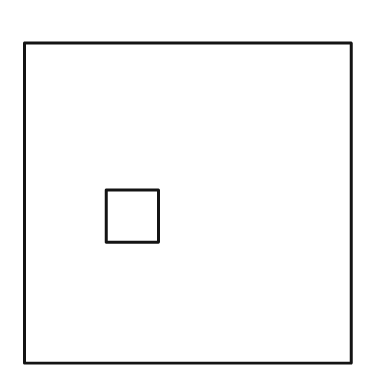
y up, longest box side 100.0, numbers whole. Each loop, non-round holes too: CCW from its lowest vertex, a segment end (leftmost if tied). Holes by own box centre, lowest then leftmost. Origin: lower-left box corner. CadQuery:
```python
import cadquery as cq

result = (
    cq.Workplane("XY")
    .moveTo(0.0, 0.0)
    .lineTo(100.0, 0.0)
    .lineTo(100.0, 98.0)
    .lineTo(0.0, 98.0)
    .close()
    .moveTo(25.0, 37.0)
    .lineTo(41.0, 37.0)
    .lineTo(41.0, 53.0)
    .lineTo(25.0, 53.0)
    .close()
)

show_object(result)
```